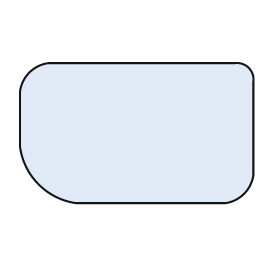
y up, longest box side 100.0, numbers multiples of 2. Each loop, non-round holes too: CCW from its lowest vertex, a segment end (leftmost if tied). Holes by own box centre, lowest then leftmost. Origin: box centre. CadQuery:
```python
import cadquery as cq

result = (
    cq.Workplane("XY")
    .moveTo(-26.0, -30.0)
    .lineTo(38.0, -30.0)
    .threePointArc((46.0, -26.0), (50.0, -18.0))
    .lineTo(50.0, 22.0)
    .threePointArc((48.0, 28.0), (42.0, 30.0))
    .lineTo(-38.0, 30.0)
    .threePointArc((-46.0, 26.0), (-50.0, 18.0))
    .lineTo(-50.0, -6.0)
    .threePointArc((-42.0, -22.0), (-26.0, -30.0))
    .close()
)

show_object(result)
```